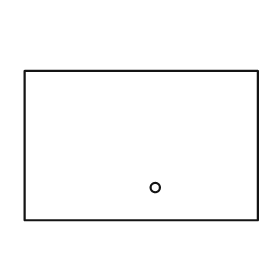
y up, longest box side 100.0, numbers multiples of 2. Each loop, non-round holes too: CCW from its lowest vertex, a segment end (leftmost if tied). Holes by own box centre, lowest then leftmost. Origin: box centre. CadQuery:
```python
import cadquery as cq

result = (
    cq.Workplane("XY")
    .moveTo(-50.0, -32.0)
    .lineTo(50.0, -32.0)
    .lineTo(50.0, 32.0)
    .lineTo(-50.0, 32.0)
    .close()
    .moveTo(6.0, -18.0)
    .circle(2.0)
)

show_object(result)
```